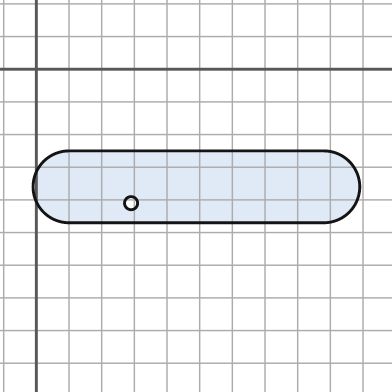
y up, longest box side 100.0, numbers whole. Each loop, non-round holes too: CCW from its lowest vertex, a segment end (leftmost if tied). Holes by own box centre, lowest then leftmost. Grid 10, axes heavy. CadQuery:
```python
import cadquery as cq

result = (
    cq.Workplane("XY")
    .moveTo(10.0, -47.0)
    .lineTo(88.0, -47.0)
    .threePointArc((99.0, -36.0), (88.0, -25.0))
    .lineTo(10.0, -25.0)
    .threePointArc((-1.0, -36.0), (10.0, -47.0))
    .close()
    .moveTo(29.0, -41.0)
    .circle(2.0)
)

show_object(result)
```